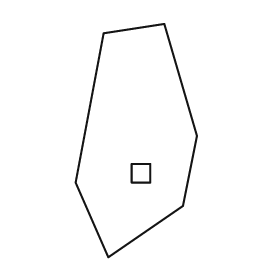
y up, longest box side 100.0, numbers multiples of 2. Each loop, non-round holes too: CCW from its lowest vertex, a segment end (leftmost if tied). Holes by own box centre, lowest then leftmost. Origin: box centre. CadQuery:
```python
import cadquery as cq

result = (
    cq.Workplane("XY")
    .moveTo(-12.0, -50.0)
    .lineTo(20.0, -28.0)
    .lineTo(26.0, 2.0)
    .lineTo(12.0, 50.0)
    .lineTo(-14.0, 46.0)
    .lineTo(-26.0, -18.0)
    .close()
    .moveTo(-2.0, -18.0)
    .lineTo(6.0, -18.0)
    .lineTo(6.0, -10.0)
    .lineTo(-2.0, -10.0)
    .close()
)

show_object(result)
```